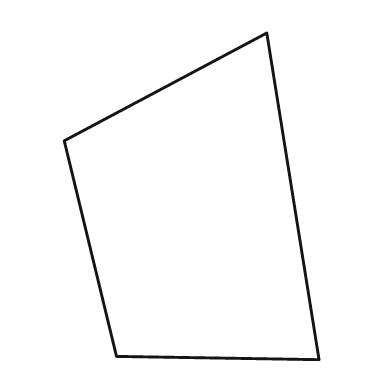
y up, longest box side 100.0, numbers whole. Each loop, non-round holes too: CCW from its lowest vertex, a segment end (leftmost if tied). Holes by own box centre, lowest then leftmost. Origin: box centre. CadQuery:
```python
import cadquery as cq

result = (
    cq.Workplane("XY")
    .moveTo(39.0, -50.0)
    .lineTo(23.0, 50.0)
    .lineTo(-39.0, 17.0)
    .lineTo(-23.0, -49.0)
    .close()
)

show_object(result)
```